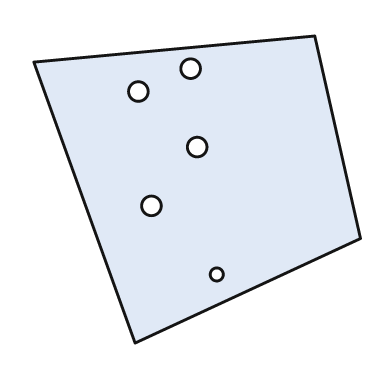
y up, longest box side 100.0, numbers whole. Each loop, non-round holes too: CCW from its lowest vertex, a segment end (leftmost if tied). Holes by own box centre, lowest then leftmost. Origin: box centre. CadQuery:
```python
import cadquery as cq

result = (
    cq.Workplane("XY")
    .moveTo(-19.0, -47.0)
    .lineTo(50.0, -15.0)
    .lineTo(36.0, 47.0)
    .lineTo(-50.0, 39.0)
    .close()
    .moveTo(6.0, -26.0)
    .circle(2.0)
    .moveTo(-14.0, -5.0)
    .circle(3.0)
    .moveTo(0.0, 13.0)
    .circle(3.0)
    .moveTo(-18.0, 30.0)
    .circle(3.0)
    .moveTo(-2.0, 37.0)
    .circle(3.0)
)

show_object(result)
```